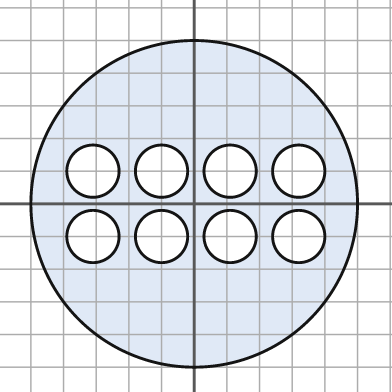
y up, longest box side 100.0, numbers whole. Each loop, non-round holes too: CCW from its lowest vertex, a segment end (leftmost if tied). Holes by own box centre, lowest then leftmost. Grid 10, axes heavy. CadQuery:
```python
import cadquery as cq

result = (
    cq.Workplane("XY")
    .moveTo(0.0, 0.0)
    .circle(50.0)
    .moveTo(-31.0, -10.0)
    .circle(8.0)
    .moveTo(-10.0, -10.0)
    .circle(8.0)
    .moveTo(11.0, -10.0)
    .circle(8.0)
    .moveTo(32.0, -10.0)
    .circle(8.0)
    .moveTo(-31.0, 10.0)
    .circle(8.0)
    .moveTo(-10.0, 10.0)
    .circle(8.0)
    .moveTo(11.0, 10.0)
    .circle(8.0)
    .moveTo(32.0, 10.0)
    .circle(8.0)
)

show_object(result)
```